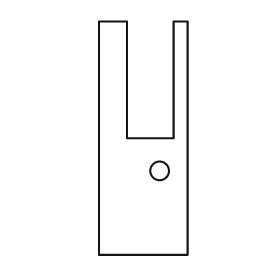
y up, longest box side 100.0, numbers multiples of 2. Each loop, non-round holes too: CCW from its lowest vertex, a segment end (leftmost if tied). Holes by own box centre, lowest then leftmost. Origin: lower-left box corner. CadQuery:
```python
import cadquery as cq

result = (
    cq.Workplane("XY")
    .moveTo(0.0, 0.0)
    .lineTo(38.0, 0.0)
    .lineTo(38.0, 100.0)
    .lineTo(32.0, 100.0)
    .lineTo(32.0, 50.0)
    .lineTo(12.0, 50.0)
    .lineTo(12.0, 100.0)
    .lineTo(0.0, 100.0)
    .close()
    .moveTo(26.0, 36.0)
    .circle(4.0)
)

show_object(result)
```